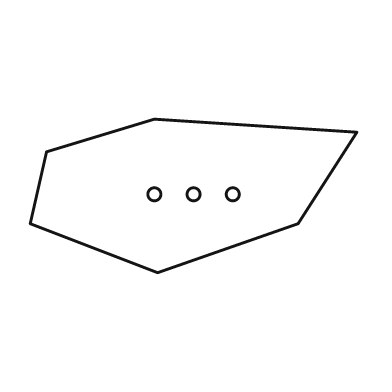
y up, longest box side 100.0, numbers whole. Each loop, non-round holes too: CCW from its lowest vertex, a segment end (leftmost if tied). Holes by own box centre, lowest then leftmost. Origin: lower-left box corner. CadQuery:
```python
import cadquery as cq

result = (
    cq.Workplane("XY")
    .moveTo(39.0, 0.0)
    .lineTo(82.0, 15.0)
    .lineTo(100.0, 43.0)
    .lineTo(38.0, 47.0)
    .lineTo(5.0, 37.0)
    .lineTo(0.0, 15.0)
    .close()
    .moveTo(38.0, 24.0)
    .circle(2.0)
    .moveTo(50.0, 24.0)
    .circle(2.0)
    .moveTo(62.0, 24.0)
    .circle(2.0)
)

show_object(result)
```